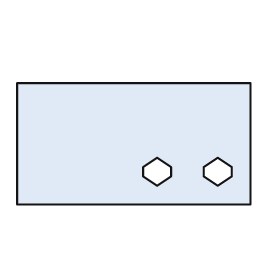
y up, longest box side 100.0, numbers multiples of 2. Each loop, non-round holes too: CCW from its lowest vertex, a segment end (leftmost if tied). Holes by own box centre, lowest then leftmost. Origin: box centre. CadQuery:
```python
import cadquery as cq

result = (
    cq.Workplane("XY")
    .moveTo(-50.0, -26.0)
    .lineTo(50.0, -26.0)
    .lineTo(50.0, 26.0)
    .lineTo(-50.0, 26.0)
    .close()
    .moveTo(10.0, -18.0)
    .lineTo(16.0, -14.0)
    .lineTo(16.0, -10.0)
    .lineTo(10.0, -6.0)
    .lineTo(4.0, -10.0)
    .lineTo(4.0, -14.0)
    .close()
    .moveTo(36.0, -18.0)
    .lineTo(42.0, -14.0)
    .lineTo(42.0, -10.0)
    .lineTo(36.0, -6.0)
    .lineTo(30.0, -10.0)
    .lineTo(30.0, -14.0)
    .close()
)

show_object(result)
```